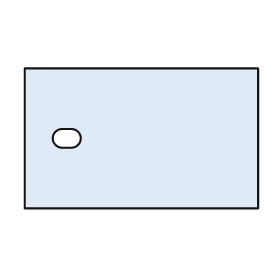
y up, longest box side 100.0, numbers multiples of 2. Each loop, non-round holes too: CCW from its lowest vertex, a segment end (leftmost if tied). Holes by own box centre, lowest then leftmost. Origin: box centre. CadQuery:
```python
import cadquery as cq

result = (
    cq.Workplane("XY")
    .moveTo(-50.0, -30.0)
    .lineTo(50.0, -30.0)
    .lineTo(50.0, 30.0)
    .lineTo(-50.0, 30.0)
    .close()
    .moveTo(-34.0, -4.0)
    .lineTo(-30.0, -4.0)
    .threePointArc((-26.0, 0.0), (-30.0, 4.0))
    .lineTo(-34.0, 4.0)
    .threePointArc((-38.0, 0.0), (-34.0, -4.0))
    .close()
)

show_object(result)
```